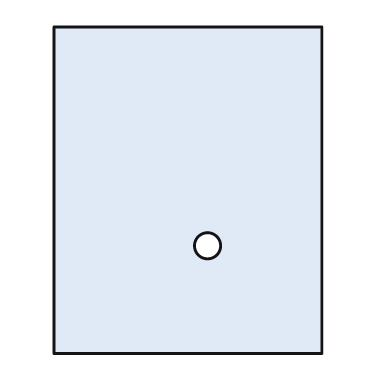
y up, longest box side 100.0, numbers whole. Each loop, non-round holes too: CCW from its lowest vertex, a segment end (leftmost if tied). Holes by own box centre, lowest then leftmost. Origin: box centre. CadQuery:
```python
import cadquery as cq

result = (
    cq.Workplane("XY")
    .moveTo(-41.0, -50.0)
    .lineTo(41.0, -50.0)
    .lineTo(41.0, 50.0)
    .lineTo(-41.0, 50.0)
    .close()
    .moveTo(6.0, -17.0)
    .circle(4.0)
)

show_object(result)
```